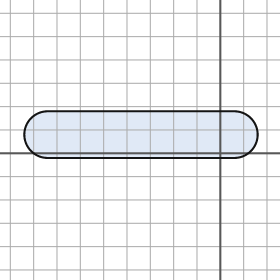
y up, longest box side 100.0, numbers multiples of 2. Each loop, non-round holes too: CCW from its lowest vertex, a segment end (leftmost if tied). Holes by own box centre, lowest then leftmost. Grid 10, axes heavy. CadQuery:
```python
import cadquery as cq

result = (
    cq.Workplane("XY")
    .moveTo(-74.0, -2.0)
    .lineTo(6.0, -2.0)
    .threePointArc((16.0, 8.0), (6.0, 18.0))
    .lineTo(-74.0, 18.0)
    .threePointArc((-84.0, 8.0), (-74.0, -2.0))
    .close()
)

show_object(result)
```